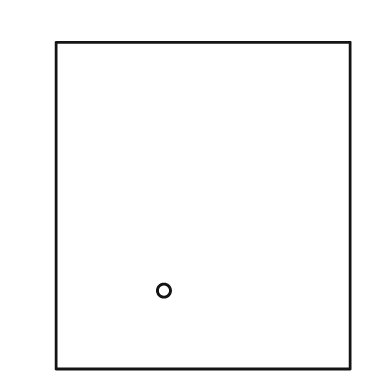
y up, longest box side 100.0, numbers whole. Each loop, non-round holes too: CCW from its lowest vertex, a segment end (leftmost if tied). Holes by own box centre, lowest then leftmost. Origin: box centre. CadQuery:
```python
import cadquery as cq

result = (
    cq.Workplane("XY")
    .moveTo(-45.0, -50.0)
    .lineTo(45.0, -50.0)
    .lineTo(45.0, 50.0)
    .lineTo(-45.0, 50.0)
    .close()
    .moveTo(-12.0, -26.0)
    .circle(2.0)
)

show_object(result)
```